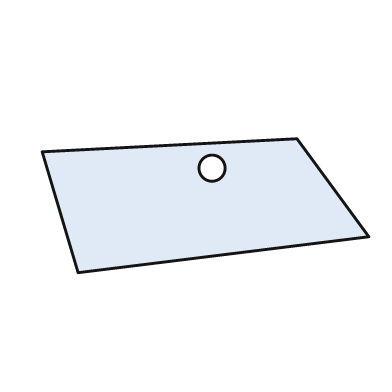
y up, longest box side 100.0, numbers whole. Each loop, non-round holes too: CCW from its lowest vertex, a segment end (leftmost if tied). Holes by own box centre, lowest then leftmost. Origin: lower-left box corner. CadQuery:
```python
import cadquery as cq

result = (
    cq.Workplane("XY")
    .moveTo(11.0, 0.0)
    .lineTo(100.0, 11.0)
    .lineTo(78.0, 41.0)
    .lineTo(0.0, 37.0)
    .close()
    .moveTo(52.0, 32.0)
    .circle(4.0)
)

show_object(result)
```